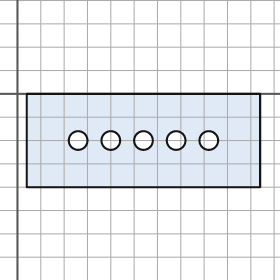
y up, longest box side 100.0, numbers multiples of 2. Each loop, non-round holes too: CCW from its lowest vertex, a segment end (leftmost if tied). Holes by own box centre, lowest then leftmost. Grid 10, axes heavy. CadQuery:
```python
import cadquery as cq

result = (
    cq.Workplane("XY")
    .moveTo(4.0, -40.0)
    .lineTo(104.0, -40.0)
    .lineTo(104.0, 0.0)
    .lineTo(4.0, 0.0)
    .close()
    .moveTo(26.0, -20.0)
    .circle(4.0)
    .moveTo(40.0, -20.0)
    .circle(4.0)
    .moveTo(54.0, -20.0)
    .circle(4.0)
    .moveTo(68.0, -20.0)
    .circle(4.0)
    .moveTo(82.0, -20.0)
    .circle(4.0)
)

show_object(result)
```